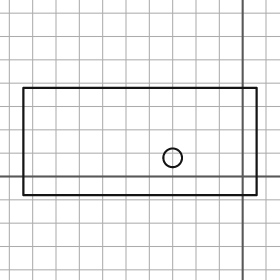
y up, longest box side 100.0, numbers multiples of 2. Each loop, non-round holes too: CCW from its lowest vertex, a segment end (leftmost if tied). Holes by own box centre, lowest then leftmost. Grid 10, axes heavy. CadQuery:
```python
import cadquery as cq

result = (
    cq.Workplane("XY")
    .moveTo(-94.0, -8.0)
    .lineTo(6.0, -8.0)
    .lineTo(6.0, 38.0)
    .lineTo(-94.0, 38.0)
    .close()
    .moveTo(-30.0, 8.0)
    .circle(4.0)
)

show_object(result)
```